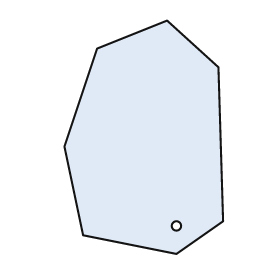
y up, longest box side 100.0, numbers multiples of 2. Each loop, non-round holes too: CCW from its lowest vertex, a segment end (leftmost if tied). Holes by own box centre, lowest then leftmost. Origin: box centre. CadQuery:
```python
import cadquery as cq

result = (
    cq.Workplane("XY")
    .moveTo(14.0, -50.0)
    .lineTo(34.0, -36.0)
    .lineTo(32.0, 30.0)
    .lineTo(10.0, 50.0)
    .lineTo(-20.0, 38.0)
    .lineTo(-34.0, -4.0)
    .lineTo(-26.0, -42.0)
    .close()
    .moveTo(14.0, -38.0)
    .circle(2.0)
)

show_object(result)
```